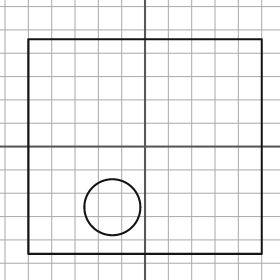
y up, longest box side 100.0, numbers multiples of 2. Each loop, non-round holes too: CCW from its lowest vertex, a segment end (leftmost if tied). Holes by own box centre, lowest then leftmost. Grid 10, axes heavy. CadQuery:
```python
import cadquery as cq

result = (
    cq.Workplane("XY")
    .moveTo(-50.0, -46.0)
    .lineTo(50.0, -46.0)
    .lineTo(50.0, 46.0)
    .lineTo(-50.0, 46.0)
    .close()
    .moveTo(-14.0, -26.0)
    .circle(12.0)
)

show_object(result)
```